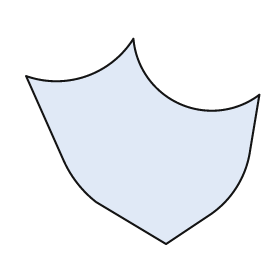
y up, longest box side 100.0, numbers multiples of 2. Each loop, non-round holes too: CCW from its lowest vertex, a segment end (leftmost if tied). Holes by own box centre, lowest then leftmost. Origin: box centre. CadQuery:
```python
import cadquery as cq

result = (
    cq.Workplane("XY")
    .moveTo(10.0, -44.0)
    .lineTo(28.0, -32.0)
    .threePointArc((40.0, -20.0), (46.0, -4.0))
    .lineTo(50.0, 20.0)
    .threePointArc((16.0, 16.0), (-4.0, 44.0))
    .threePointArc((-24.0, 28.0), (-50.0, 28.0))
    .lineTo(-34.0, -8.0)
    .threePointArc((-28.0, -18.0), (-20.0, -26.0))
    .close()
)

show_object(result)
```